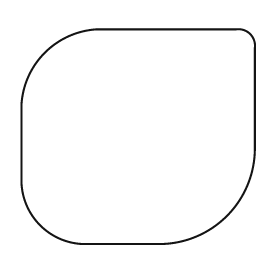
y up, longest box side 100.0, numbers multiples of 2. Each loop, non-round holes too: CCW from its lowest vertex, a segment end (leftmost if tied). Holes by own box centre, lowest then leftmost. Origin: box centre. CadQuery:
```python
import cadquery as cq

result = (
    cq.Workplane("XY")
    .moveTo(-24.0, -46.0)
    .lineTo(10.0, -46.0)
    .threePointArc((38.0, -34.0), (50.0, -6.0))
    .lineTo(50.0, 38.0)
    .threePointArc((48.0, 44.0), (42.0, 46.0))
    .lineTo(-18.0, 46.0)
    .threePointArc((-40.0, 36.0), (-50.0, 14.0))
    .lineTo(-50.0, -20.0)
    .threePointArc((-42.0, -38.0), (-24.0, -46.0))
    .close()
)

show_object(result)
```